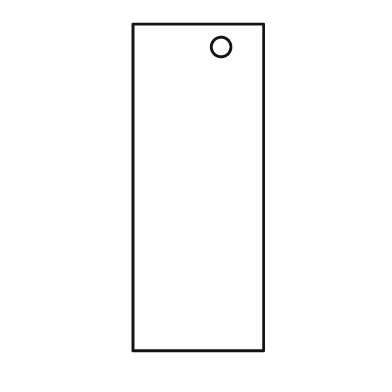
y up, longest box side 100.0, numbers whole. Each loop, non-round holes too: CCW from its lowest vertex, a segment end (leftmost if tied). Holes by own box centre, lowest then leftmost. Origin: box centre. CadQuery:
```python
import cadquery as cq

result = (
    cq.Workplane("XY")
    .moveTo(-20.0, -50.0)
    .lineTo(20.0, -50.0)
    .lineTo(20.0, 50.0)
    .lineTo(-20.0, 50.0)
    .close()
    .moveTo(7.0, 43.0)
    .circle(3.0)
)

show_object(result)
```